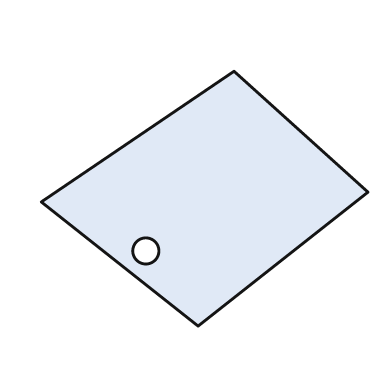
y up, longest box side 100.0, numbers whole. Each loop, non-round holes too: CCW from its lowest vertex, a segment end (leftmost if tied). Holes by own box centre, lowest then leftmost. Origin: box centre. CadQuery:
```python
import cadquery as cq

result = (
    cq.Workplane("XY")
    .moveTo(-2.0, -39.0)
    .lineTo(50.0, 2.0)
    .lineTo(9.0, 39.0)
    .lineTo(-50.0, -1.0)
    .close()
    .moveTo(-18.0, -16.0)
    .circle(4.0)
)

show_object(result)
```